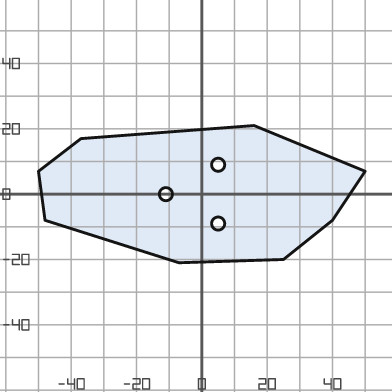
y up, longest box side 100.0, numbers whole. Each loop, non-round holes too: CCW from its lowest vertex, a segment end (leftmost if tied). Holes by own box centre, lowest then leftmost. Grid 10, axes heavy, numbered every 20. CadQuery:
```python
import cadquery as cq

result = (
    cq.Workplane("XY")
    .moveTo(-7.0, -21.0)
    .lineTo(25.0, -20.0)
    .lineTo(40.0, -8.0)
    .lineTo(50.0, 7.0)
    .lineTo(16.0, 21.0)
    .lineTo(-37.0, 17.0)
    .lineTo(-50.0, 7.0)
    .lineTo(-48.0, -8.0)
    .close()
    .moveTo(5.0, -9.0)
    .circle(2.0)
    .moveTo(-11.0, 0.0)
    .circle(2.0)
    .moveTo(5.0, 9.0)
    .circle(2.0)
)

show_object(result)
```